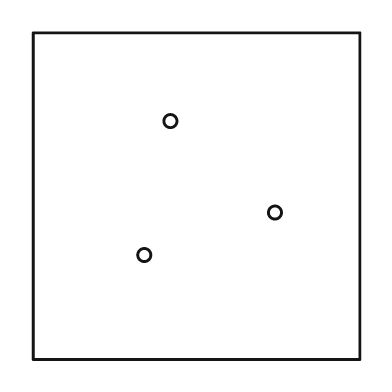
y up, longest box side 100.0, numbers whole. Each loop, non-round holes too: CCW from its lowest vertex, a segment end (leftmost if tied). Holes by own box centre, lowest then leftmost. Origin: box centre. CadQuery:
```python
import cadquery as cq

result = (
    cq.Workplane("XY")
    .moveTo(-50.0, -50.0)
    .lineTo(50.0, -50.0)
    .lineTo(50.0, 50.0)
    .lineTo(-50.0, 50.0)
    .close()
    .moveTo(-16.0, -18.0)
    .circle(2.0)
    .moveTo(24.0, -5.0)
    .circle(2.0)
    .moveTo(-8.0, 23.0)
    .circle(2.0)
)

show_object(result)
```